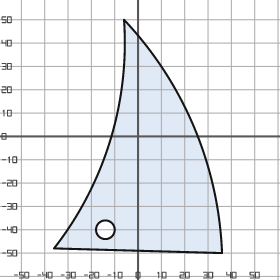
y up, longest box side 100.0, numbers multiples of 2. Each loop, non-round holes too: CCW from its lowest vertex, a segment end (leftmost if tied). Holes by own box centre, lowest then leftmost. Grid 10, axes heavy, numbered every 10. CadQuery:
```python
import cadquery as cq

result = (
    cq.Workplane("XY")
    .moveTo(36.0, -50.0)
    .threePointArc((24.0, 4.0), (-6.0, 50.0))
    .threePointArc((-12.0, -2.0), (-36.0, -48.0))
    .close()
    .moveTo(-14.0, -40.0)
    .circle(4.0)
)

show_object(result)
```